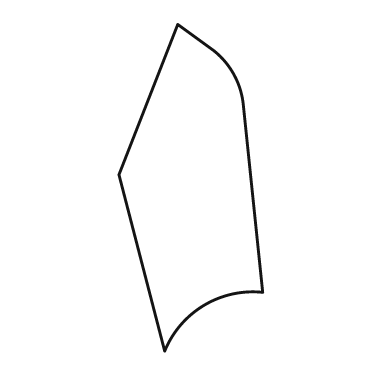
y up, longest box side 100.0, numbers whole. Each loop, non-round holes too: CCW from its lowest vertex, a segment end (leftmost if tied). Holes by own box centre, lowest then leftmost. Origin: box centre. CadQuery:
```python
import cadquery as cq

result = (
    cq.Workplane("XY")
    .moveTo(-8.0, -50.0)
    .threePointArc((4.0, -36.0), (22.0, -32.0))
    .lineTo(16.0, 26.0)
    .threePointArc((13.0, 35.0), (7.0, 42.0))
    .lineTo(-4.0, 50.0)
    .lineTo(-22.0, 4.0)
    .close()
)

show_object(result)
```